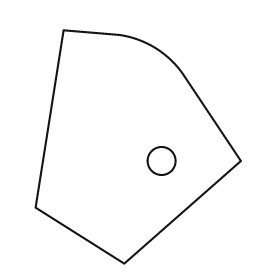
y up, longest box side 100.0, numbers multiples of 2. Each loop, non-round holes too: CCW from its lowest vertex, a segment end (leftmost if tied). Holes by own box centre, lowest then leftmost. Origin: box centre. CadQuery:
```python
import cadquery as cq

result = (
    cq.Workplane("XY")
    .moveTo(-6.0, -50.0)
    .lineTo(44.0, -6.0)
    .lineTo(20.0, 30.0)
    .threePointArc((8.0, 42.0), (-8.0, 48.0))
    .lineTo(-32.0, 50.0)
    .lineTo(-44.0, -26.0)
    .close()
    .moveTo(10.0, -6.0)
    .circle(6.0)
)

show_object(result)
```